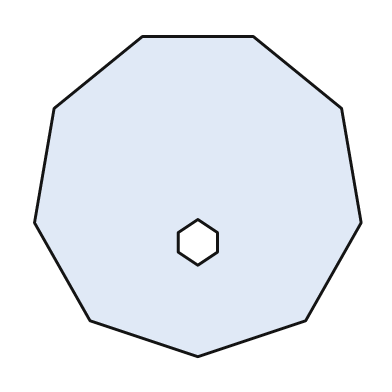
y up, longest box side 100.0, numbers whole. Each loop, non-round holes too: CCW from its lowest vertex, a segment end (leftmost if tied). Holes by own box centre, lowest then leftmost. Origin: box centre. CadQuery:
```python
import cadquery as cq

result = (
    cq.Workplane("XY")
    .moveTo(0.0, -49.0)
    .lineTo(33.0, -38.0)
    .lineTo(50.0, -8.0)
    .lineTo(44.0, 27.0)
    .lineTo(17.0, 49.0)
    .lineTo(-17.0, 49.0)
    .lineTo(-44.0, 27.0)
    .lineTo(-50.0, -8.0)
    .lineTo(-33.0, -38.0)
    .close()
    .moveTo(0.0, -21.0)
    .lineTo(6.0, -17.0)
    .lineTo(6.0, -11.0)
    .lineTo(0.0, -7.0)
    .lineTo(-6.0, -11.0)
    .lineTo(-6.0, -17.0)
    .close()
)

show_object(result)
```